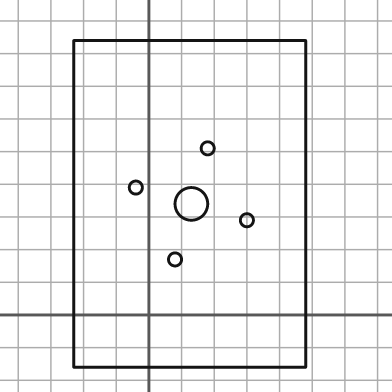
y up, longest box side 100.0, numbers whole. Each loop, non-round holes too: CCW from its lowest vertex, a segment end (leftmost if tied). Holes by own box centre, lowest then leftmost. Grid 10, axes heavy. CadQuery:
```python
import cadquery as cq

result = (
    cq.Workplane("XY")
    .moveTo(-23.0, -16.0)
    .lineTo(48.0, -16.0)
    .lineTo(48.0, 84.0)
    .lineTo(-23.0, 84.0)
    .close()
    .moveTo(8.0, 17.0)
    .circle(2.0)
    .moveTo(30.0, 29.0)
    .circle(2.0)
    .moveTo(13.0, 34.0)
    .circle(5.0)
    .moveTo(-4.0, 39.0)
    .circle(2.0)
    .moveTo(18.0, 51.0)
    .circle(2.0)
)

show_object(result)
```